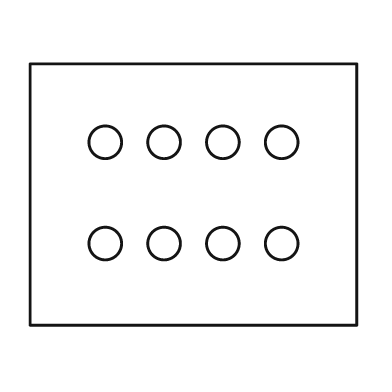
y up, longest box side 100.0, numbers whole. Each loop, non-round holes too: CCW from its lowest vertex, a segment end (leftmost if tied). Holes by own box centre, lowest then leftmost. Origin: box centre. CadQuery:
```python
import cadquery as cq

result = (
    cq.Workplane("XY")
    .moveTo(-50.0, -40.0)
    .lineTo(50.0, -40.0)
    .lineTo(50.0, 40.0)
    .lineTo(-50.0, 40.0)
    .close()
    .moveTo(-27.0, -15.0)
    .circle(5.0)
    .moveTo(-9.0, -15.0)
    .circle(5.0)
    .moveTo(9.0, -15.0)
    .circle(5.0)
    .moveTo(27.0, -15.0)
    .circle(5.0)
    .moveTo(-27.0, 16.0)
    .circle(5.0)
    .moveTo(-9.0, 16.0)
    .circle(5.0)
    .moveTo(9.0, 16.0)
    .circle(5.0)
    .moveTo(27.0, 16.0)
    .circle(5.0)
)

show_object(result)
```